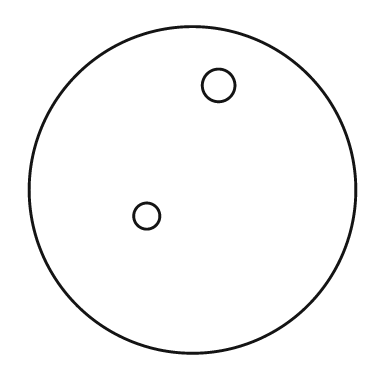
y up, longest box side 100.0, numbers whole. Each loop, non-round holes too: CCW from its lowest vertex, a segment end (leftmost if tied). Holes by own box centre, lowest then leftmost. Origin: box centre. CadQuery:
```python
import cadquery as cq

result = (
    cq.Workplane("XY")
    .moveTo(0.0, 0.0)
    .circle(50.0)
    .moveTo(-14.0, -8.0)
    .circle(4.0)
    .moveTo(8.0, 32.0)
    .circle(5.0)
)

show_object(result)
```